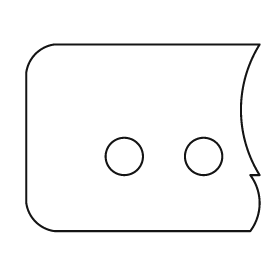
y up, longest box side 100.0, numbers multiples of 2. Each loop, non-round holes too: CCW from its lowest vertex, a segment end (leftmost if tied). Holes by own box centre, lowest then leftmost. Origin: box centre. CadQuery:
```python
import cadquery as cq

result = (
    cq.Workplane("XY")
    .moveTo(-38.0, -40.0)
    .lineTo(46.0, -40.0)
    .threePointArc((50.0, -28.0), (46.0, -16.0))
    .lineTo(50.0, -16.0)
    .threePointArc((42.0, 12.0), (50.0, 40.0))
    .lineTo(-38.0, 40.0)
    .threePointArc((-46.0, 36.0), (-50.0, 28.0))
    .lineTo(-50.0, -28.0)
    .threePointArc((-46.0, -36.0), (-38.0, -40.0))
    .close()
    .moveTo(-8.0, -8.0)
    .circle(8.0)
    .moveTo(26.0, -8.0)
    .circle(8.0)
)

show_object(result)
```